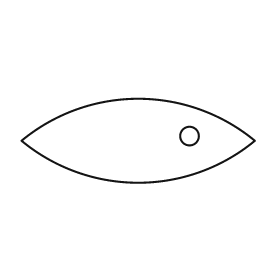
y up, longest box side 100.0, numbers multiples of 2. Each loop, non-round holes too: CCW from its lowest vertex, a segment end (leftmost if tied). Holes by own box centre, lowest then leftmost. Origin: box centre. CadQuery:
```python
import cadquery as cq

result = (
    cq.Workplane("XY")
    .moveTo(-50.0, 0.0)
    .threePointArc((0.0, -18.0), (50.0, 0.0))
    .threePointArc((0.0, 18.0), (-50.0, 0.0))
    .close()
    .moveTo(22.0, 2.0)
    .circle(4.0)
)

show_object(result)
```